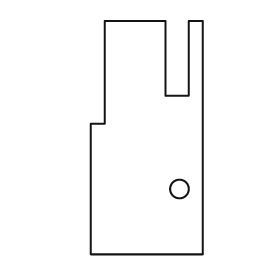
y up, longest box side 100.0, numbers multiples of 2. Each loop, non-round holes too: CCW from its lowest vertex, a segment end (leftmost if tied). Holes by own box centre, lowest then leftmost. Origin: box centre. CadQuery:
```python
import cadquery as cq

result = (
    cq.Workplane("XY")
    .moveTo(-24.0, -50.0)
    .lineTo(24.0, -50.0)
    .lineTo(24.0, 50.0)
    .lineTo(18.0, 50.0)
    .lineTo(18.0, 18.0)
    .lineTo(8.0, 18.0)
    .lineTo(8.0, 50.0)
    .lineTo(-18.0, 50.0)
    .lineTo(-18.0, 6.0)
    .lineTo(-24.0, 6.0)
    .close()
    .moveTo(14.0, -22.0)
    .circle(4.0)
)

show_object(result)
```